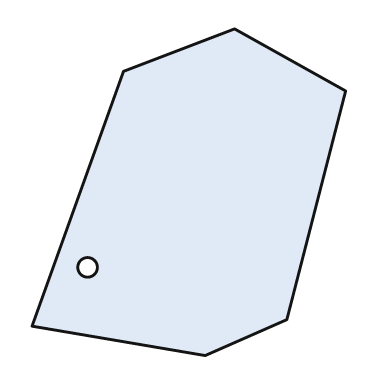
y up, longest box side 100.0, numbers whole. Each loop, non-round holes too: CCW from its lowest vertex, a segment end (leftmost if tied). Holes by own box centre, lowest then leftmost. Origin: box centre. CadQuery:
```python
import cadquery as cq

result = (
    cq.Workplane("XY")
    .moveTo(5.0, -50.0)
    .lineTo(30.0, -39.0)
    .lineTo(48.0, 31.0)
    .lineTo(14.0, 50.0)
    .lineTo(-20.0, 37.0)
    .lineTo(-48.0, -41.0)
    .close()
    .moveTo(-31.0, -23.0)
    .circle(3.0)
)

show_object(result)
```